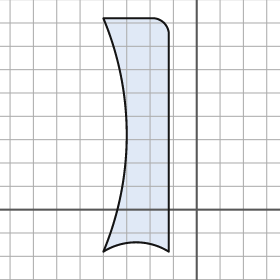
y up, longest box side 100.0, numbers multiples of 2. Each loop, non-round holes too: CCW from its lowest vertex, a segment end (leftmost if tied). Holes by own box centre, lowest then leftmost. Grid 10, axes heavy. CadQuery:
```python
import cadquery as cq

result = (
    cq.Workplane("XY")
    .moveTo(-40.0, -18.0)
    .threePointArc((-26.0, -14.0), (-12.0, -18.0))
    .lineTo(-12.0, 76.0)
    .threePointArc((-14.0, 80.0), (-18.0, 82.0))
    .lineTo(-40.0, 82.0)
    .threePointArc((-30.0, 32.0), (-40.0, -18.0))
    .close()
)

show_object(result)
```